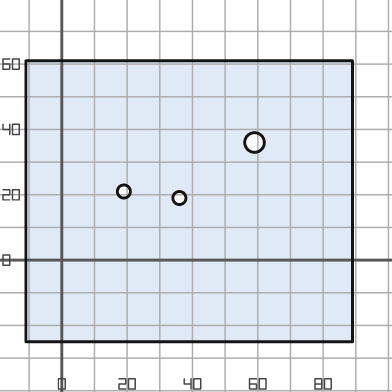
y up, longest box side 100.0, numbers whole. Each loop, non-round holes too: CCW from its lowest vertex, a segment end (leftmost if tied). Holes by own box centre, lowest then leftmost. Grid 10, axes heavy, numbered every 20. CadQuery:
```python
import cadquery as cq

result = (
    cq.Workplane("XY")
    .moveTo(-11.0, -25.0)
    .lineTo(89.0, -25.0)
    .lineTo(89.0, 61.0)
    .lineTo(-11.0, 61.0)
    .close()
    .moveTo(36.0, 19.0)
    .circle(2.0)
    .moveTo(19.0, 21.0)
    .circle(2.0)
    .moveTo(59.0, 36.0)
    .circle(3.0)
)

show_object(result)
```